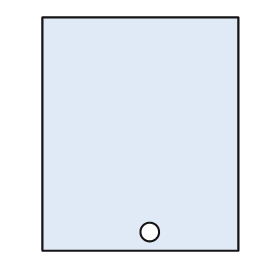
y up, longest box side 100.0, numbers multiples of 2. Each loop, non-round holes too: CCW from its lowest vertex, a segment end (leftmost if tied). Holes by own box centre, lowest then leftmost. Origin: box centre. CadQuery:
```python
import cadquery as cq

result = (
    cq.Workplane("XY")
    .moveTo(-42.0, -50.0)
    .lineTo(42.0, -50.0)
    .lineTo(42.0, 50.0)
    .lineTo(-42.0, 50.0)
    .close()
    .moveTo(4.0, -42.0)
    .circle(4.0)
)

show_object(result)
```